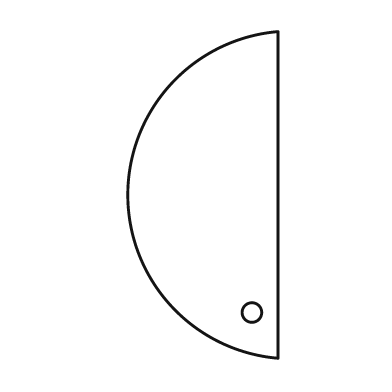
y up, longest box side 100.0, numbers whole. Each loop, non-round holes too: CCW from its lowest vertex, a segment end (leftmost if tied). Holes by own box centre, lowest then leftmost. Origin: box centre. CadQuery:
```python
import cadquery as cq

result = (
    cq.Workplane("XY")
    .moveTo(23.0, -50.0)
    .lineTo(23.0, 50.0)
    .threePointArc((-23.0, 0.0), (23.0, -50.0))
    .close()
    .moveTo(15.0, -36.0)
    .circle(3.0)
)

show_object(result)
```